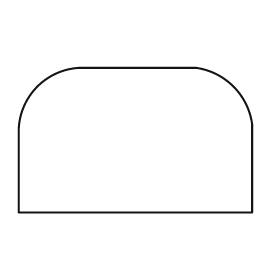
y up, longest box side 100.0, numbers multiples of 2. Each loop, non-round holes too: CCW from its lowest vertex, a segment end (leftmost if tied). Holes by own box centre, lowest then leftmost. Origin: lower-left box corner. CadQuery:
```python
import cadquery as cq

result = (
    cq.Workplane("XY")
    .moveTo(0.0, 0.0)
    .lineTo(100.0, 0.0)
    .lineTo(100.0, 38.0)
    .threePointArc((92.0, 54.0), (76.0, 62.0))
    .lineTo(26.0, 62.0)
    .threePointArc((8.0, 54.0), (0.0, 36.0))
    .close()
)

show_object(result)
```